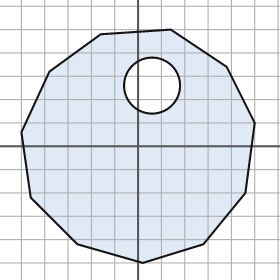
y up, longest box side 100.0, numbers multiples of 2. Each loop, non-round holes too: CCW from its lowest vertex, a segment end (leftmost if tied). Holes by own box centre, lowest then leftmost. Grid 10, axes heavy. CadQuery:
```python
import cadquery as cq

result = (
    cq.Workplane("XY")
    .moveTo(2.0, -50.0)
    .lineTo(28.0, -42.0)
    .lineTo(46.0, -20.0)
    .lineTo(50.0, 10.0)
    .lineTo(38.0, 34.0)
    .lineTo(14.0, 50.0)
    .lineTo(-16.0, 48.0)
    .lineTo(-38.0, 32.0)
    .lineTo(-50.0, 6.0)
    .lineTo(-46.0, -22.0)
    .lineTo(-26.0, -42.0)
    .close()
    .moveTo(6.0, 26.0)
    .circle(12.0)
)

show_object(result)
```